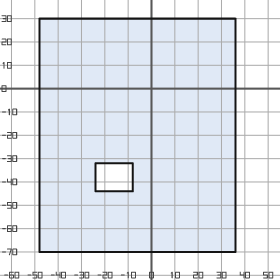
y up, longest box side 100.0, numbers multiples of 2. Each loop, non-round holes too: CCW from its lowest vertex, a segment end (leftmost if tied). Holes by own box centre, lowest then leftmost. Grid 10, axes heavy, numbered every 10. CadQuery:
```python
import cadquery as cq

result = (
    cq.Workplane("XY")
    .moveTo(-48.0, -70.0)
    .lineTo(36.0, -70.0)
    .lineTo(36.0, 30.0)
    .lineTo(-48.0, 30.0)
    .close()
    .moveTo(-24.0, -44.0)
    .lineTo(-8.0, -44.0)
    .lineTo(-8.0, -32.0)
    .lineTo(-24.0, -32.0)
    .close()
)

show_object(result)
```